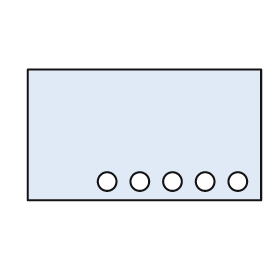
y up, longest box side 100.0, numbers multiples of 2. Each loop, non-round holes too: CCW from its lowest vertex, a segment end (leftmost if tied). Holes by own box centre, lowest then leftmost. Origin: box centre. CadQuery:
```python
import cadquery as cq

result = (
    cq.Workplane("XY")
    .moveTo(-50.0, -28.0)
    .lineTo(50.0, -28.0)
    .lineTo(50.0, 28.0)
    .lineTo(-50.0, 28.0)
    .close()
    .moveTo(-16.0, -20.0)
    .circle(4.0)
    .moveTo(-2.0, -20.0)
    .circle(4.0)
    .moveTo(12.0, -20.0)
    .circle(4.0)
    .moveTo(26.0, -20.0)
    .circle(4.0)
    .moveTo(40.0, -20.0)
    .circle(4.0)
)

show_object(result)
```